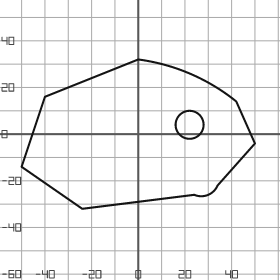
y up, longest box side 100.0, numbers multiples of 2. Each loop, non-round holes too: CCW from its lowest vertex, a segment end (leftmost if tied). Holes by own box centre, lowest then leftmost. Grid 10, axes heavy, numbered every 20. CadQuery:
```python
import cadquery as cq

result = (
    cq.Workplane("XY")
    .moveTo(-24.0, -32.0)
    .lineTo(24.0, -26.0)
    .threePointArc((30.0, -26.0), (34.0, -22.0))
    .lineTo(50.0, -4.0)
    .lineTo(42.0, 14.0)
    .threePointArc((22.0, 26.0), (0.0, 32.0))
    .lineTo(-40.0, 16.0)
    .lineTo(-50.0, -14.0)
    .close()
    .moveTo(22.0, 4.0)
    .circle(6.0)
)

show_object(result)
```